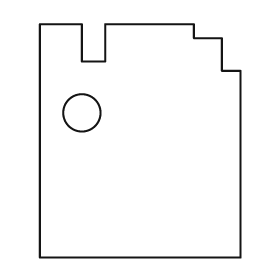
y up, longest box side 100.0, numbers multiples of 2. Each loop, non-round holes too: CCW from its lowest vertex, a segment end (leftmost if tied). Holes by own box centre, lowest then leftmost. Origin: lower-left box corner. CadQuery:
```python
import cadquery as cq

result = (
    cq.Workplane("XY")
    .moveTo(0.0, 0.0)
    .lineTo(86.0, 0.0)
    .lineTo(86.0, 80.0)
    .lineTo(78.0, 80.0)
    .lineTo(78.0, 94.0)
    .lineTo(66.0, 94.0)
    .lineTo(66.0, 100.0)
    .lineTo(28.0, 100.0)
    .lineTo(28.0, 84.0)
    .lineTo(18.0, 84.0)
    .lineTo(18.0, 100.0)
    .lineTo(0.0, 100.0)
    .close()
    .moveTo(18.0, 62.0)
    .circle(8.0)
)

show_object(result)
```